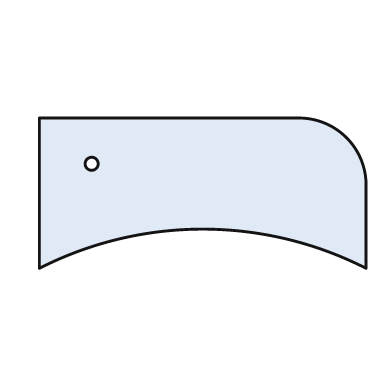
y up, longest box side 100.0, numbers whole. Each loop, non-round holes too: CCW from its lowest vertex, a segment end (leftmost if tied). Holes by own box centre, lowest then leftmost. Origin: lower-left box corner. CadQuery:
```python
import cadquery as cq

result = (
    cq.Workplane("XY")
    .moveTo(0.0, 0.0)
    .threePointArc((50.0, 12.0), (100.0, 0.0))
    .lineTo(100.0, 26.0)
    .threePointArc((94.0, 40.0), (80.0, 46.0))
    .lineTo(0.0, 46.0)
    .close()
    .moveTo(16.0, 32.0)
    .circle(2.0)
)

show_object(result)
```